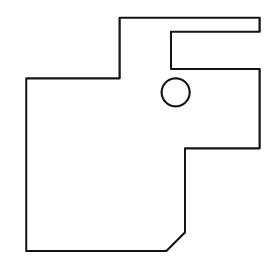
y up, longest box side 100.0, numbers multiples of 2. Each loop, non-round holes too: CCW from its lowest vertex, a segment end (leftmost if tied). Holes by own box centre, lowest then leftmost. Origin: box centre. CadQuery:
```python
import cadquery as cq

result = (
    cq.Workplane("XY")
    .moveTo(-50.0, -50.0)
    .lineTo(10.0, -50.0)
    .lineTo(18.0, -42.0)
    .lineTo(18.0, -6.0)
    .lineTo(50.0, -6.0)
    .lineTo(50.0, 28.0)
    .lineTo(12.0, 28.0)
    .lineTo(12.0, 44.0)
    .lineTo(50.0, 44.0)
    .lineTo(50.0, 50.0)
    .lineTo(-10.0, 50.0)
    .lineTo(-10.0, 24.0)
    .lineTo(-50.0, 24.0)
    .close()
    .moveTo(14.0, 18.0)
    .circle(6.0)
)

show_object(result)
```